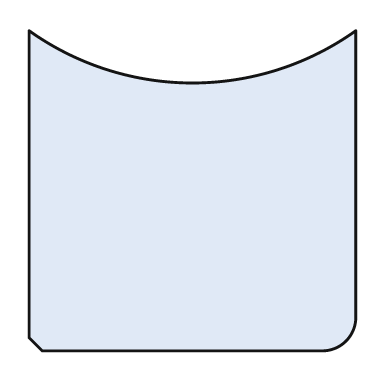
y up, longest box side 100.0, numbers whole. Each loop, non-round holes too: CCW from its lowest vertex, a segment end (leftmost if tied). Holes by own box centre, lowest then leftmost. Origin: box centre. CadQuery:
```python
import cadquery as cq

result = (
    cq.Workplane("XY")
    .moveTo(-46.0, -49.0)
    .lineTo(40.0, -49.0)
    .threePointArc((47.0, -46.0), (50.0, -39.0))
    .lineTo(50.0, 49.0)
    .threePointArc((0.0, 33.0), (-50.0, 49.0))
    .lineTo(-50.0, -45.0)
    .close()
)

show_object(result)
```